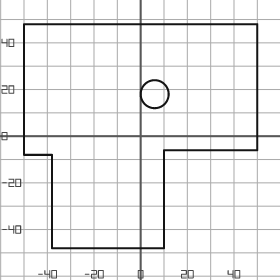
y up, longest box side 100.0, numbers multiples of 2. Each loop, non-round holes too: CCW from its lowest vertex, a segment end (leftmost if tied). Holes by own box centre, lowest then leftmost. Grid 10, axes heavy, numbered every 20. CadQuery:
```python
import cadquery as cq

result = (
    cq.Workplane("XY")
    .moveTo(-38.0, -48.0)
    .lineTo(10.0, -48.0)
    .lineTo(10.0, -6.0)
    .lineTo(50.0, -6.0)
    .lineTo(50.0, 48.0)
    .lineTo(-50.0, 48.0)
    .lineTo(-50.0, -8.0)
    .lineTo(-38.0, -8.0)
    .close()
    .moveTo(6.0, 18.0)
    .circle(6.0)
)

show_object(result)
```